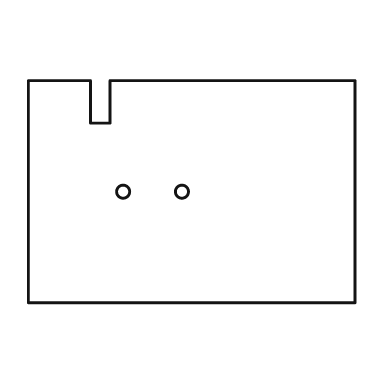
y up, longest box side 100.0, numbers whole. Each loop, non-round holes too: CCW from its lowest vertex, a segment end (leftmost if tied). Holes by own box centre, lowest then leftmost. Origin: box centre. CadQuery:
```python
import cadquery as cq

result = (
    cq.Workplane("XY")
    .moveTo(-50.0, -34.0)
    .lineTo(50.0, -34.0)
    .lineTo(50.0, 34.0)
    .lineTo(-25.0, 34.0)
    .lineTo(-25.0, 21.0)
    .lineTo(-31.0, 21.0)
    .lineTo(-31.0, 34.0)
    .lineTo(-50.0, 34.0)
    .close()
    .moveTo(-21.0, 0.0)
    .circle(2.0)
    .moveTo(-3.0, 0.0)
    .circle(2.0)
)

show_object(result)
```